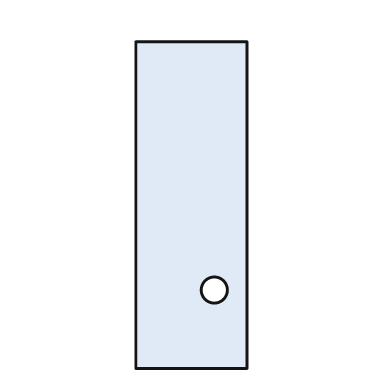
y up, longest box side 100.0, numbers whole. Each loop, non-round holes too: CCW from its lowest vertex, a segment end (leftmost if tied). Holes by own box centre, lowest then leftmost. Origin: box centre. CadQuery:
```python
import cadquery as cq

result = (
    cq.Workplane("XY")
    .moveTo(-17.0, -50.0)
    .lineTo(17.0, -50.0)
    .lineTo(17.0, 50.0)
    .lineTo(-17.0, 50.0)
    .close()
    .moveTo(7.0, -26.0)
    .circle(4.0)
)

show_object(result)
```